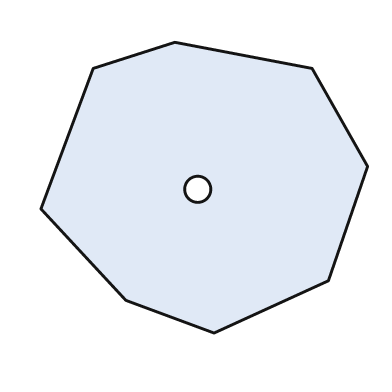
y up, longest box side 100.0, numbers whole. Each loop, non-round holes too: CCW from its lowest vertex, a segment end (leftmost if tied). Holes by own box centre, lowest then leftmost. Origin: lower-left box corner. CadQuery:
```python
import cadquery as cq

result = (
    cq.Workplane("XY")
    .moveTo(53.0, 0.0)
    .lineTo(88.0, 16.0)
    .lineTo(100.0, 51.0)
    .lineTo(83.0, 81.0)
    .lineTo(41.0, 89.0)
    .lineTo(16.0, 81.0)
    .lineTo(0.0, 38.0)
    .lineTo(26.0, 10.0)
    .close()
    .moveTo(48.0, 44.0)
    .circle(4.0)
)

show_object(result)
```